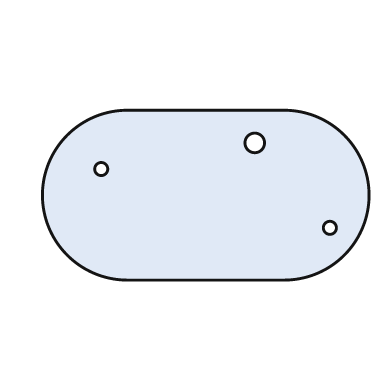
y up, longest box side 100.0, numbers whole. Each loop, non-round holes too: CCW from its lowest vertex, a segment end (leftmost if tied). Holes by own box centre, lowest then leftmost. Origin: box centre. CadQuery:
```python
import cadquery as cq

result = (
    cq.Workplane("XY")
    .moveTo(-24.0, -26.0)
    .lineTo(24.0, -26.0)
    .threePointArc((50.0, 0.0), (24.0, 26.0))
    .lineTo(-24.0, 26.0)
    .threePointArc((-50.0, 0.0), (-24.0, -26.0))
    .close()
    .moveTo(38.0, -10.0)
    .circle(2.0)
    .moveTo(-32.0, 8.0)
    .circle(2.0)
    .moveTo(15.0, 16.0)
    .circle(3.0)
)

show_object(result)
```